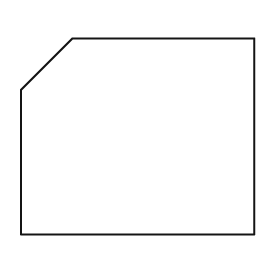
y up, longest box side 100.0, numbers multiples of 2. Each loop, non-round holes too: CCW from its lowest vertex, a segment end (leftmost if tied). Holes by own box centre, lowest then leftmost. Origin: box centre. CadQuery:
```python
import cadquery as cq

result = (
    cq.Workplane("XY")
    .moveTo(-50.0, -42.0)
    .lineTo(50.0, -42.0)
    .lineTo(50.0, 42.0)
    .lineTo(-28.0, 42.0)
    .lineTo(-50.0, 20.0)
    .close()
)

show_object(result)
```